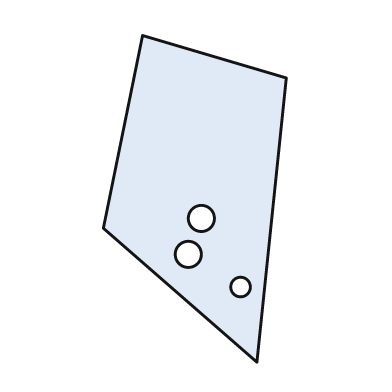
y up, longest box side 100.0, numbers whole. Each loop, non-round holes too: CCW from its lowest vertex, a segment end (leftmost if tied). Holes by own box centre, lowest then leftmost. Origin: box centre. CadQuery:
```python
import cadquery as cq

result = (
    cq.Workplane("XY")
    .moveTo(19.0, -50.0)
    .lineTo(28.0, 37.0)
    .lineTo(-16.0, 50.0)
    .lineTo(-28.0, -9.0)
    .close()
    .moveTo(14.0, -27.0)
    .circle(3.0)
    .moveTo(-2.0, -17.0)
    .circle(4.0)
    .moveTo(2.0, -6.0)
    .circle(4.0)
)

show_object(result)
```